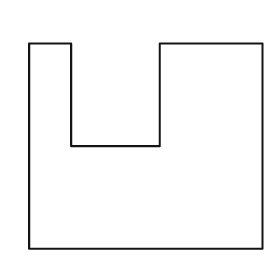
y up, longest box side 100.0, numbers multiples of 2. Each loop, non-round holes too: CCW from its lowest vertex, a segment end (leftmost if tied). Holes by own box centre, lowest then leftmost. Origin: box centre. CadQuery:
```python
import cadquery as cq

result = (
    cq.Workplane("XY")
    .moveTo(-50.0, -44.0)
    .lineTo(50.0, -44.0)
    .lineTo(50.0, 44.0)
    .lineTo(6.0, 44.0)
    .lineTo(6.0, 0.0)
    .lineTo(-32.0, 0.0)
    .lineTo(-32.0, 44.0)
    .lineTo(-50.0, 44.0)
    .close()
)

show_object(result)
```